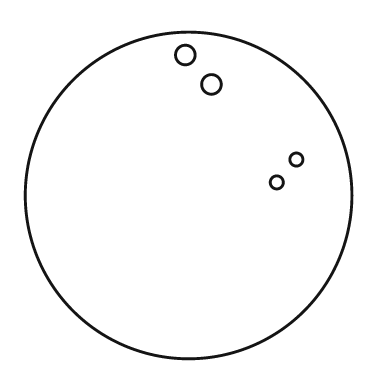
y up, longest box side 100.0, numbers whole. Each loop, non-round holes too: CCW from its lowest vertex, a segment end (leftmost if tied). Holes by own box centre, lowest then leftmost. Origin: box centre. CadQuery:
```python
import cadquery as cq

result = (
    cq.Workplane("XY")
    .moveTo(0.0, 0.0)
    .circle(50.0)
    .moveTo(27.0, 4.0)
    .circle(2.0)
    .moveTo(33.0, 11.0)
    .circle(2.0)
    .moveTo(7.0, 34.0)
    .circle(3.0)
    .moveTo(-1.0, 43.0)
    .circle(3.0)
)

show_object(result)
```